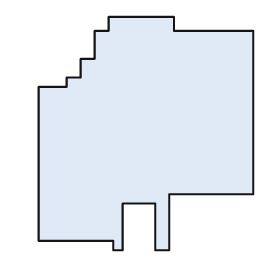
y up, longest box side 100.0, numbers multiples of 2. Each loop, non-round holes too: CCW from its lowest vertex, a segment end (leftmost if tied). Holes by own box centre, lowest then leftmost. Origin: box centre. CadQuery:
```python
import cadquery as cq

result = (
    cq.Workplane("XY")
    .moveTo(-14.0, -50.0)
    .lineTo(-10.0, -50.0)
    .lineTo(-10.0, -30.0)
    .lineTo(4.0, -30.0)
    .lineTo(4.0, -50.0)
    .lineTo(10.0, -50.0)
    .lineTo(10.0, -26.0)
    .lineTo(46.0, -26.0)
    .lineTo(46.0, 44.0)
    .lineTo(12.0, 44.0)
    .lineTo(12.0, 50.0)
    .lineTo(-16.0, 50.0)
    .lineTo(-16.0, 44.0)
    .lineTo(-22.0, 44.0)
    .lineTo(-22.0, 32.0)
    .lineTo(-28.0, 32.0)
    .lineTo(-28.0, 24.0)
    .lineTo(-34.0, 24.0)
    .lineTo(-34.0, 20.0)
    .lineTo(-46.0, 20.0)
    .lineTo(-46.0, -46.0)
    .lineTo(-14.0, -46.0)
    .close()
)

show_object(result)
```